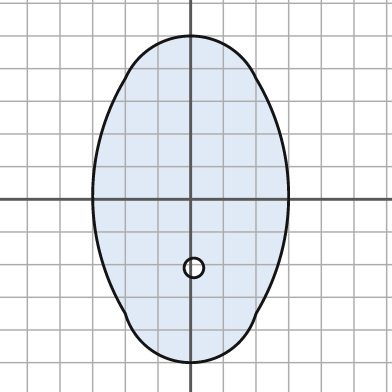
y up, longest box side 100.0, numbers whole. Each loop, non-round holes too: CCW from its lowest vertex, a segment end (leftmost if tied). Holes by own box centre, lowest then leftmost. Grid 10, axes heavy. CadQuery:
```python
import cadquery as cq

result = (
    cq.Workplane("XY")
    .moveTo(-20.0, -35.0)
    .threePointArc((0.0, -50.0), (20.0, -35.0))
    .threePointArc((30.0, 1.0), (20.0, 37.0))
    .threePointArc((0.0, 50.0), (-20.0, 37.0))
    .threePointArc((-30.0, 1.0), (-20.0, -35.0))
    .close()
    .moveTo(1.0, -21.0)
    .circle(3.0)
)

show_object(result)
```